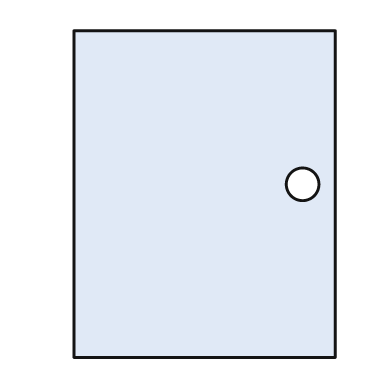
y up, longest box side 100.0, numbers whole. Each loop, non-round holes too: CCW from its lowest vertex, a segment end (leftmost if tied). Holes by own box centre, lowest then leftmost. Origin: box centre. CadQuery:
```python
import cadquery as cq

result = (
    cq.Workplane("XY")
    .moveTo(-40.0, -50.0)
    .lineTo(40.0, -50.0)
    .lineTo(40.0, 50.0)
    .lineTo(-40.0, 50.0)
    .close()
    .moveTo(30.0, 3.0)
    .circle(5.0)
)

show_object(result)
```